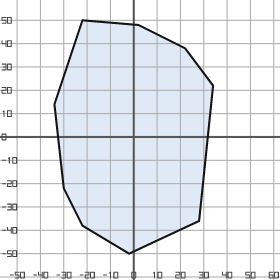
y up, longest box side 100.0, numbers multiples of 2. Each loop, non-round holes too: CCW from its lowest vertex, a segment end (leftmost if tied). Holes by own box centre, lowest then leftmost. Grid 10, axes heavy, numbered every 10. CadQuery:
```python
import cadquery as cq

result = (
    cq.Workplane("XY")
    .moveTo(-2.0, -50.0)
    .lineTo(28.0, -36.0)
    .lineTo(34.0, 22.0)
    .lineTo(22.0, 38.0)
    .lineTo(2.0, 48.0)
    .lineTo(-22.0, 50.0)
    .lineTo(-34.0, 14.0)
    .lineTo(-30.0, -22.0)
    .lineTo(-22.0, -38.0)
    .close()
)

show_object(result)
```